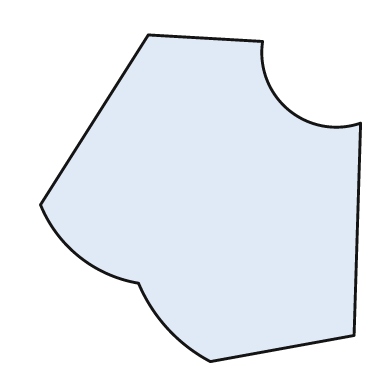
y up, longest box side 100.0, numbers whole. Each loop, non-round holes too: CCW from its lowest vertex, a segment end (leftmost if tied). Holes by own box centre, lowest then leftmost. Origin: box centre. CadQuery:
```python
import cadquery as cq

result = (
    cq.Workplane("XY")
    .moveTo(3.0, -50.0)
    .lineTo(47.0, -42.0)
    .lineTo(49.0, 23.0)
    .threePointArc((27.0, 27.0), (19.0, 48.0))
    .lineTo(-16.0, 50.0)
    .lineTo(-49.0, -2.0)
    .threePointArc((-37.0, -18.0), (-19.0, -26.0))
    .threePointArc((-10.0, -40.0), (3.0, -50.0))
    .close()
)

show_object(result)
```